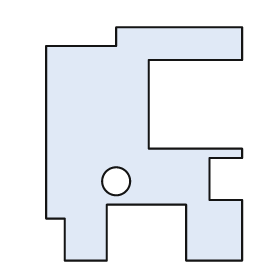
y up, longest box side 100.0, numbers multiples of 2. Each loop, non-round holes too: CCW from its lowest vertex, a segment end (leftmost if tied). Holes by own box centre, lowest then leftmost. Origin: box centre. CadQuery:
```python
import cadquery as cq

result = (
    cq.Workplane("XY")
    .moveTo(-34.0, -50.0)
    .lineTo(-16.0, -50.0)
    .lineTo(-16.0, -26.0)
    .lineTo(18.0, -26.0)
    .lineTo(18.0, -50.0)
    .lineTo(42.0, -50.0)
    .lineTo(42.0, -24.0)
    .lineTo(28.0, -24.0)
    .lineTo(28.0, -6.0)
    .lineTo(42.0, -6.0)
    .lineTo(42.0, -2.0)
    .lineTo(2.0, -2.0)
    .lineTo(2.0, 36.0)
    .lineTo(42.0, 36.0)
    .lineTo(42.0, 50.0)
    .lineTo(-12.0, 50.0)
    .lineTo(-12.0, 42.0)
    .lineTo(-42.0, 42.0)
    .lineTo(-42.0, -32.0)
    .lineTo(-34.0, -32.0)
    .close()
    .moveTo(-12.0, -16.0)
    .circle(6.0)
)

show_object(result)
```